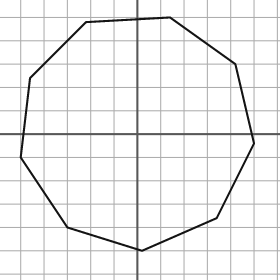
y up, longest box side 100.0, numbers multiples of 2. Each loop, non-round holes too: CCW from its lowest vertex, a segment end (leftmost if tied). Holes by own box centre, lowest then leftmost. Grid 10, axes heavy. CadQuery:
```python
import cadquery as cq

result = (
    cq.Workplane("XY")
    .moveTo(2.0, -50.0)
    .lineTo(34.0, -36.0)
    .lineTo(50.0, -4.0)
    .lineTo(42.0, 30.0)
    .lineTo(14.0, 50.0)
    .lineTo(-22.0, 48.0)
    .lineTo(-46.0, 24.0)
    .lineTo(-50.0, -10.0)
    .lineTo(-30.0, -40.0)
    .close()
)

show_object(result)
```